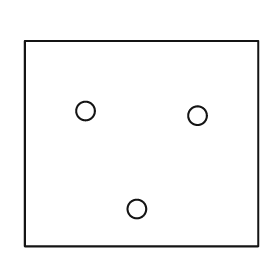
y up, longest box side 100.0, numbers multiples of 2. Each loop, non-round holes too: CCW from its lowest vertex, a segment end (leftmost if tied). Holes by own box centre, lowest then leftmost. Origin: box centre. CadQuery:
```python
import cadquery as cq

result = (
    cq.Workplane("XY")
    .moveTo(-50.0, -44.0)
    .lineTo(50.0, -44.0)
    .lineTo(50.0, 44.0)
    .lineTo(-50.0, 44.0)
    .close()
    .moveTo(-2.0, -28.0)
    .circle(4.0)
    .moveTo(24.0, 12.0)
    .circle(4.0)
    .moveTo(-24.0, 14.0)
    .circle(4.0)
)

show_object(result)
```